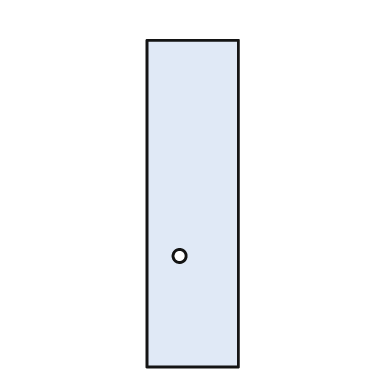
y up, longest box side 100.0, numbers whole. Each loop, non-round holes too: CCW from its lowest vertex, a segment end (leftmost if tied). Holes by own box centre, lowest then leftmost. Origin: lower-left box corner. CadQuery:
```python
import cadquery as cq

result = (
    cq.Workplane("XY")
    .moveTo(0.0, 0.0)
    .lineTo(28.0, 0.0)
    .lineTo(28.0, 100.0)
    .lineTo(0.0, 100.0)
    .close()
    .moveTo(10.0, 34.0)
    .circle(2.0)
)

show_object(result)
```